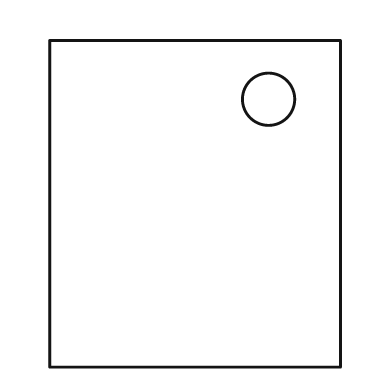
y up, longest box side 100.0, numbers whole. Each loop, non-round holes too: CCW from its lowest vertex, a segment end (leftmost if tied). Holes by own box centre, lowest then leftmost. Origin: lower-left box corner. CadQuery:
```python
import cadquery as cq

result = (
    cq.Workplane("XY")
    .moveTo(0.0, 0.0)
    .lineTo(89.0, 0.0)
    .lineTo(89.0, 100.0)
    .lineTo(0.0, 100.0)
    .close()
    .moveTo(67.0, 82.0)
    .circle(8.0)
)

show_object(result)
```